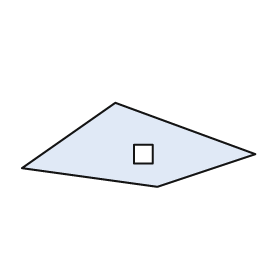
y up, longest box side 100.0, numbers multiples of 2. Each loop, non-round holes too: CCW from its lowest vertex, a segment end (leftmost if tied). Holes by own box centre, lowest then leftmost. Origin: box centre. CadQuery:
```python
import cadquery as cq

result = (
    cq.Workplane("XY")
    .moveTo(8.0, -18.0)
    .lineTo(50.0, -4.0)
    .lineTo(-10.0, 18.0)
    .lineTo(-50.0, -10.0)
    .close()
    .moveTo(-2.0, -8.0)
    .lineTo(6.0, -8.0)
    .lineTo(6.0, 0.0)
    .lineTo(-2.0, 0.0)
    .close()
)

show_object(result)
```